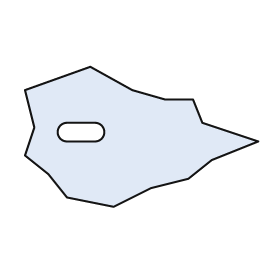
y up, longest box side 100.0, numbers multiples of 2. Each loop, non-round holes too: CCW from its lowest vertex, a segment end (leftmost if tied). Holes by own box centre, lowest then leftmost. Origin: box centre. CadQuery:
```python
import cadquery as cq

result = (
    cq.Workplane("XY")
    .moveTo(-12.0, -30.0)
    .lineTo(4.0, -22.0)
    .lineTo(20.0, -18.0)
    .lineTo(30.0, -10.0)
    .lineTo(50.0, -2.0)
    .lineTo(26.0, 6.0)
    .lineTo(22.0, 16.0)
    .lineTo(10.0, 16.0)
    .lineTo(-4.0, 20.0)
    .lineTo(-22.0, 30.0)
    .lineTo(-50.0, 20.0)
    .lineTo(-46.0, 4.0)
    .lineTo(-50.0, -8.0)
    .lineTo(-40.0, -16.0)
    .lineTo(-32.0, -26.0)
    .close()
    .moveTo(-32.0, -2.0)
    .lineTo(-20.0, -2.0)
    .threePointArc((-16.0, 2.0), (-20.0, 6.0))
    .lineTo(-32.0, 6.0)
    .threePointArc((-36.0, 2.0), (-32.0, -2.0))
    .close()
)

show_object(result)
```